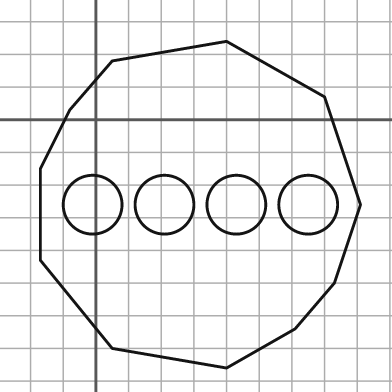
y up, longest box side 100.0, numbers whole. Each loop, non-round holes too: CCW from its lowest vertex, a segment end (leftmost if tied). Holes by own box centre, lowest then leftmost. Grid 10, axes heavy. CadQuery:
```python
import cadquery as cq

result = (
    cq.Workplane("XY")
    .moveTo(40.0, -76.0)
    .lineTo(61.0, -64.0)
    .lineTo(73.0, -50.0)
    .lineTo(81.0, -26.0)
    .lineTo(70.0, 7.0)
    .lineTo(40.0, 24.0)
    .lineTo(5.0, 18.0)
    .lineTo(-8.0, 3.0)
    .lineTo(-17.0, -15.0)
    .lineTo(-17.0, -43.0)
    .lineTo(5.0, -70.0)
    .close()
    .moveTo(-1.0, -26.0)
    .circle(9.0)
    .moveTo(21.0, -26.0)
    .circle(9.0)
    .moveTo(43.0, -26.0)
    .circle(9.0)
    .moveTo(65.0, -26.0)
    .circle(9.0)
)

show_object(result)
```